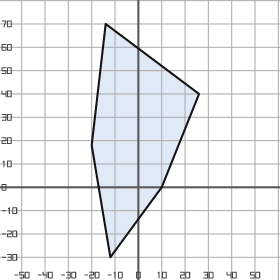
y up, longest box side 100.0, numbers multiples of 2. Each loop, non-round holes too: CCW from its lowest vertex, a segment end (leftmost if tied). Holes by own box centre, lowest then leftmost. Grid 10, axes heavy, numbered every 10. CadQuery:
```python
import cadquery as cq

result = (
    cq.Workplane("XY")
    .moveTo(-12.0, -30.0)
    .lineTo(10.0, 0.0)
    .lineTo(26.0, 40.0)
    .lineTo(-14.0, 70.0)
    .lineTo(-20.0, 18.0)
    .close()
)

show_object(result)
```